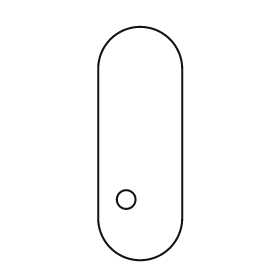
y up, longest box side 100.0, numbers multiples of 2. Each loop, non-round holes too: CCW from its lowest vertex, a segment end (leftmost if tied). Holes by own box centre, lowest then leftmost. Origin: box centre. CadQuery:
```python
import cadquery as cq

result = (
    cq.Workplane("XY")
    .moveTo(-18.0, -32.0)
    .threePointArc((0.0, -50.0), (18.0, -32.0))
    .lineTo(18.0, 32.0)
    .threePointArc((0.0, 50.0), (-18.0, 32.0))
    .close()
    .moveTo(-6.0, -24.0)
    .circle(4.0)
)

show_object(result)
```